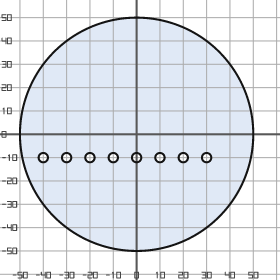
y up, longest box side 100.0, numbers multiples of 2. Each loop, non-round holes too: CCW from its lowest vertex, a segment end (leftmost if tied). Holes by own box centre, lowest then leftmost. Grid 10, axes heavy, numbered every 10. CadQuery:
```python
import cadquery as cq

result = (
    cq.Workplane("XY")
    .moveTo(0.0, 0.0)
    .circle(50.0)
    .moveTo(-40.0, -10.0)
    .circle(2.0)
    .moveTo(-30.0, -10.0)
    .circle(2.0)
    .moveTo(-20.0, -10.0)
    .circle(2.0)
    .moveTo(-10.0, -10.0)
    .circle(2.0)
    .moveTo(0.0, -10.0)
    .circle(2.0)
    .moveTo(10.0, -10.0)
    .circle(2.0)
    .moveTo(20.0, -10.0)
    .circle(2.0)
    .moveTo(30.0, -10.0)
    .circle(2.0)
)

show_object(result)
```